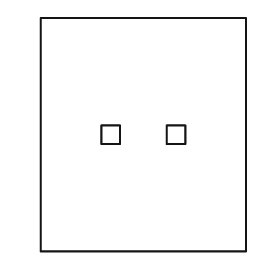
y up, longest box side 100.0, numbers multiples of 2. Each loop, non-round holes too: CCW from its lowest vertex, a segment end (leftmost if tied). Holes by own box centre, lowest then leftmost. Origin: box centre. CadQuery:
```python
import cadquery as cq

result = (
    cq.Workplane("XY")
    .moveTo(-44.0, -50.0)
    .lineTo(44.0, -50.0)
    .lineTo(44.0, 50.0)
    .lineTo(-44.0, 50.0)
    .close()
    .moveTo(-18.0, -4.0)
    .lineTo(-10.0, -4.0)
    .lineTo(-10.0, 4.0)
    .lineTo(-18.0, 4.0)
    .close()
    .moveTo(10.0, -4.0)
    .lineTo(18.0, -4.0)
    .lineTo(18.0, 4.0)
    .lineTo(10.0, 4.0)
    .close()
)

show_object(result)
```